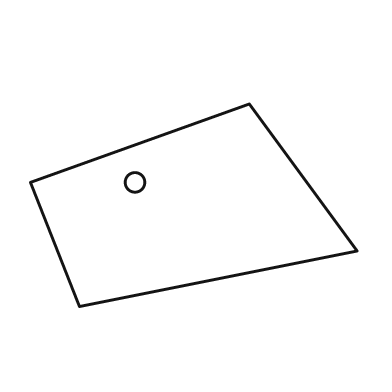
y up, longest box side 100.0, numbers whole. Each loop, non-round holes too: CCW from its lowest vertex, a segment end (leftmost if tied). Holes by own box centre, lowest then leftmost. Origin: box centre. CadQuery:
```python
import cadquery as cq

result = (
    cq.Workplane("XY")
    .moveTo(-35.0, -31.0)
    .lineTo(50.0, -14.0)
    .lineTo(17.0, 31.0)
    .lineTo(-50.0, 7.0)
    .close()
    .moveTo(-18.0, 7.0)
    .circle(3.0)
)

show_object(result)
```